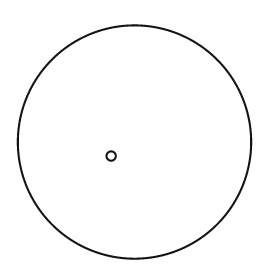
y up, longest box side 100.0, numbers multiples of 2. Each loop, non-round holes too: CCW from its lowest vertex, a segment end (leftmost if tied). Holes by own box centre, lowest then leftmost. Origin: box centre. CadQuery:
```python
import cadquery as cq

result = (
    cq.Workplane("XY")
    .moveTo(0.0, 0.0)
    .circle(50.0)
    .moveTo(-10.0, -6.0)
    .circle(2.0)
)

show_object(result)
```